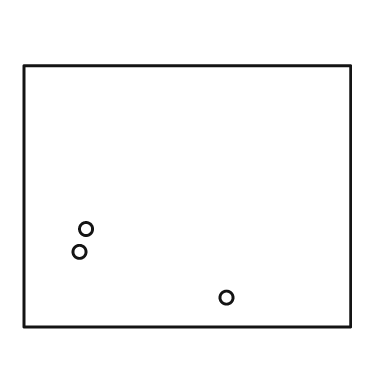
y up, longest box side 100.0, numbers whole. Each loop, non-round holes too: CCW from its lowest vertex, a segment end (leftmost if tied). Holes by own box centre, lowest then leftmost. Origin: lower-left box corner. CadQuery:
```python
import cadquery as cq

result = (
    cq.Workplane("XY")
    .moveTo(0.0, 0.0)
    .lineTo(100.0, 0.0)
    .lineTo(100.0, 80.0)
    .lineTo(0.0, 80.0)
    .close()
    .moveTo(62.0, 9.0)
    .circle(2.0)
    .moveTo(17.0, 23.0)
    .circle(2.0)
    .moveTo(19.0, 30.0)
    .circle(2.0)
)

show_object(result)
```